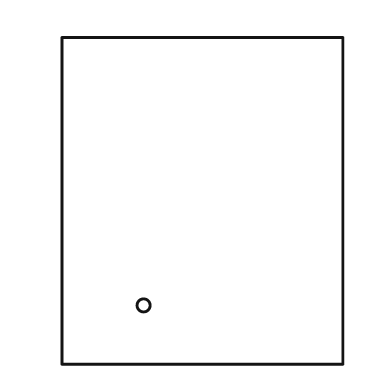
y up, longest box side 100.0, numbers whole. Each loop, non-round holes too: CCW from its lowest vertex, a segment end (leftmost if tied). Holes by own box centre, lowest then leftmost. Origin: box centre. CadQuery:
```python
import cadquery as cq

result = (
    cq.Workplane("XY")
    .moveTo(-43.0, -50.0)
    .lineTo(43.0, -50.0)
    .lineTo(43.0, 50.0)
    .lineTo(-43.0, 50.0)
    .close()
    .moveTo(-18.0, -32.0)
    .circle(2.0)
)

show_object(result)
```